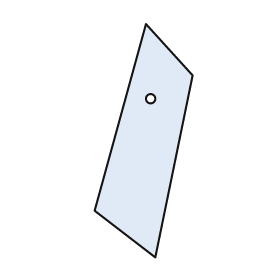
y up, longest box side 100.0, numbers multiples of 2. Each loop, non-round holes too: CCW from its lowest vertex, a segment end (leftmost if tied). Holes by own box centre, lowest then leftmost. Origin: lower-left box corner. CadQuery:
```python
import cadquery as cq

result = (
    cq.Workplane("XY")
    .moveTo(26.0, 0.0)
    .lineTo(42.0, 78.0)
    .lineTo(22.0, 100.0)
    .lineTo(0.0, 20.0)
    .close()
    .moveTo(24.0, 68.0)
    .circle(2.0)
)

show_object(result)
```